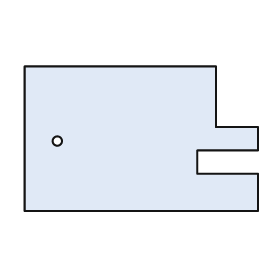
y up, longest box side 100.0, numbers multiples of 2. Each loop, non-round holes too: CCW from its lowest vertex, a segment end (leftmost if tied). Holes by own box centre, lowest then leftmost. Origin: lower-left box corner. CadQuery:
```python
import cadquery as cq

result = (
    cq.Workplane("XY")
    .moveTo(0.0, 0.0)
    .lineTo(100.0, 0.0)
    .lineTo(100.0, 16.0)
    .lineTo(74.0, 16.0)
    .lineTo(74.0, 26.0)
    .lineTo(100.0, 26.0)
    .lineTo(100.0, 36.0)
    .lineTo(82.0, 36.0)
    .lineTo(82.0, 62.0)
    .lineTo(0.0, 62.0)
    .close()
    .moveTo(14.0, 30.0)
    .circle(2.0)
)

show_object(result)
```